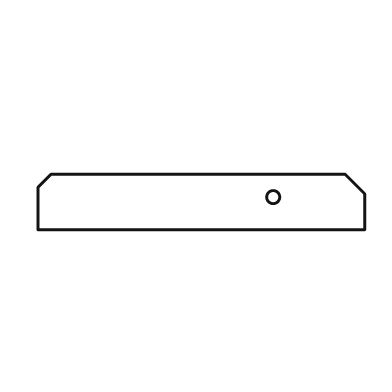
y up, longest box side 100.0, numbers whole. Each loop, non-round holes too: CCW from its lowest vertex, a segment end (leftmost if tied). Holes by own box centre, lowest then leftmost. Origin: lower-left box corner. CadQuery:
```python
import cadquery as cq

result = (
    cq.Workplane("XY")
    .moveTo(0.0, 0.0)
    .lineTo(100.0, 0.0)
    .lineTo(100.0, 11.0)
    .lineTo(94.0, 17.0)
    .lineTo(4.0, 17.0)
    .lineTo(0.0, 13.0)
    .close()
    .moveTo(72.0, 10.0)
    .circle(2.0)
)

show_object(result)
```